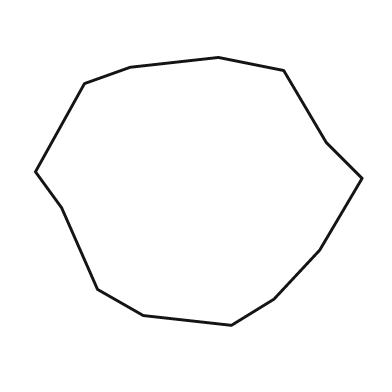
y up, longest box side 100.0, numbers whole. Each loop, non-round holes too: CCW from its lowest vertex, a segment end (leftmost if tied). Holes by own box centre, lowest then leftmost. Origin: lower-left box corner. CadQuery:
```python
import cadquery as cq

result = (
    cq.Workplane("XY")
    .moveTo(60.0, 0.0)
    .lineTo(73.0, 8.0)
    .lineTo(87.0, 23.0)
    .lineTo(100.0, 45.0)
    .lineTo(89.0, 56.0)
    .lineTo(76.0, 78.0)
    .lineTo(56.0, 82.0)
    .lineTo(29.0, 79.0)
    .lineTo(15.0, 74.0)
    .lineTo(0.0, 47.0)
    .lineTo(8.0, 36.0)
    .lineTo(19.0, 11.0)
    .lineTo(33.0, 3.0)
    .close()
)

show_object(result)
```